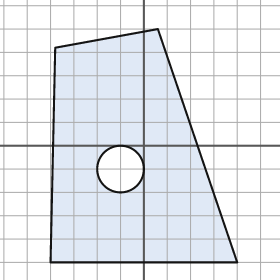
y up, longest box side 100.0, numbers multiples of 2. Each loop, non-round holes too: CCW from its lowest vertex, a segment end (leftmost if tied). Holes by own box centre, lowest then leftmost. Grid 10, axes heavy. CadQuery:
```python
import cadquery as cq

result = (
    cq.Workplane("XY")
    .moveTo(-40.0, -50.0)
    .lineTo(40.0, -50.0)
    .lineTo(6.0, 50.0)
    .lineTo(-38.0, 42.0)
    .close()
    .moveTo(-10.0, -10.0)
    .circle(10.0)
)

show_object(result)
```